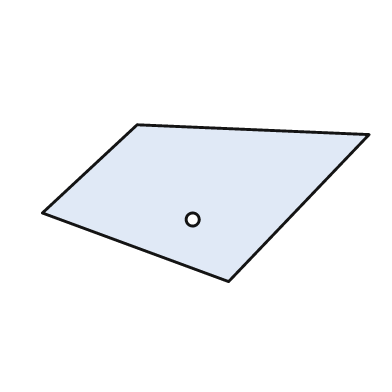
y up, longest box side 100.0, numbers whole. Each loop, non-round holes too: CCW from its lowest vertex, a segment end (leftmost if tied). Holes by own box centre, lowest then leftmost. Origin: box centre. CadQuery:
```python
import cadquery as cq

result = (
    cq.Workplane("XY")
    .moveTo(7.0, -24.0)
    .lineTo(50.0, 21.0)
    .lineTo(-21.0, 24.0)
    .lineTo(-50.0, -3.0)
    .close()
    .moveTo(-4.0, -5.0)
    .circle(2.0)
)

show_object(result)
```